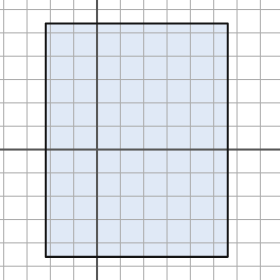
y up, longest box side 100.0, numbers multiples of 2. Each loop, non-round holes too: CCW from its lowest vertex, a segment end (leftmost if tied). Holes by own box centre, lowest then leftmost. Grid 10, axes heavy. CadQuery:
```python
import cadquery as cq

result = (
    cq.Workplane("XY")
    .moveTo(-22.0, -46.0)
    .lineTo(56.0, -46.0)
    .lineTo(56.0, 54.0)
    .lineTo(-22.0, 54.0)
    .close()
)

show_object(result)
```